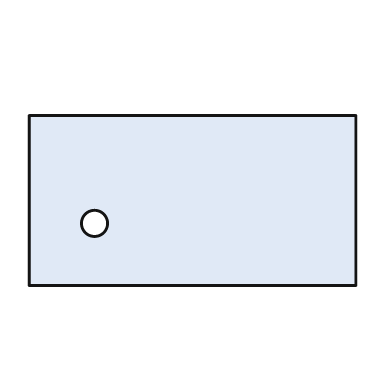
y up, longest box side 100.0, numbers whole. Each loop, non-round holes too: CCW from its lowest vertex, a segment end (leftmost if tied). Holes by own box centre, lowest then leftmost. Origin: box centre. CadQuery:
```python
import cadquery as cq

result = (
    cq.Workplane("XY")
    .moveTo(-50.0, -26.0)
    .lineTo(50.0, -26.0)
    .lineTo(50.0, 26.0)
    .lineTo(-50.0, 26.0)
    .close()
    .moveTo(-30.0, -7.0)
    .circle(4.0)
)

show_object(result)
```